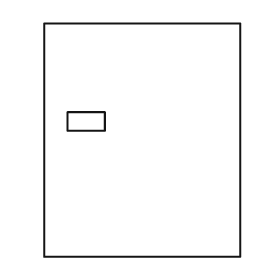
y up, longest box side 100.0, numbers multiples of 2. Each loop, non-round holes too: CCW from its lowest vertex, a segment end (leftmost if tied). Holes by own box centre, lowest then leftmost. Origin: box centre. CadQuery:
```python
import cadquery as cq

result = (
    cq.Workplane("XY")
    .moveTo(-42.0, -50.0)
    .lineTo(42.0, -50.0)
    .lineTo(42.0, 50.0)
    .lineTo(-42.0, 50.0)
    .close()
    .moveTo(-32.0, 4.0)
    .lineTo(-16.0, 4.0)
    .lineTo(-16.0, 12.0)
    .lineTo(-32.0, 12.0)
    .close()
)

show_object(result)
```